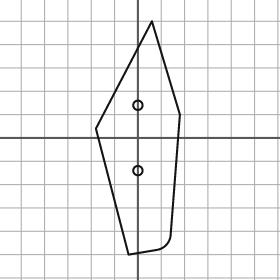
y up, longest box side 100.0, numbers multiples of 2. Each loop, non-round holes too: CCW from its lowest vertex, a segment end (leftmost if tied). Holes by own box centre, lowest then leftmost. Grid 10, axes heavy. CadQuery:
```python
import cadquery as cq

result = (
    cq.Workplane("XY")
    .moveTo(-4.0, -50.0)
    .lineTo(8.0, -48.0)
    .threePointArc((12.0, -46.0), (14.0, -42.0))
    .lineTo(18.0, 10.0)
    .lineTo(6.0, 50.0)
    .lineTo(-18.0, 4.0)
    .close()
    .moveTo(0.0, -14.0)
    .circle(2.0)
    .moveTo(0.0, 14.0)
    .circle(2.0)
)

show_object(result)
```